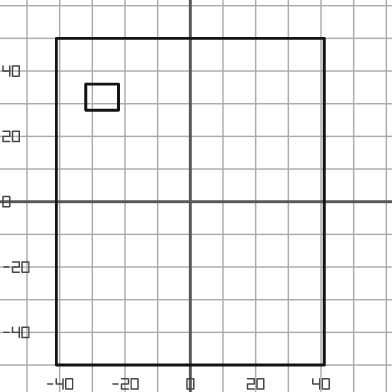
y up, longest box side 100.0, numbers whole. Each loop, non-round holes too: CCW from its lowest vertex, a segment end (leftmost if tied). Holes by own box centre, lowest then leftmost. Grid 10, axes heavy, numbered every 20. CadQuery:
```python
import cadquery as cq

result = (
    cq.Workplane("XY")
    .moveTo(-41.0, -50.0)
    .lineTo(41.0, -50.0)
    .lineTo(41.0, 50.0)
    .lineTo(-41.0, 50.0)
    .close()
    .moveTo(-32.0, 28.0)
    .lineTo(-22.0, 28.0)
    .lineTo(-22.0, 36.0)
    .lineTo(-32.0, 36.0)
    .close()
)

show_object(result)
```